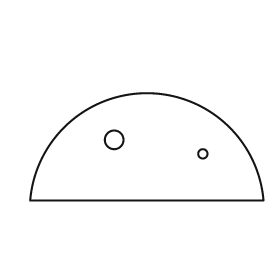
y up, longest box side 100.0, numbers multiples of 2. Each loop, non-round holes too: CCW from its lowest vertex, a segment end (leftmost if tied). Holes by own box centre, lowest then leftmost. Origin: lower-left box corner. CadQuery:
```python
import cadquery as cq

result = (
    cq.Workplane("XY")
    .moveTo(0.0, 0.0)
    .lineTo(100.0, 0.0)
    .threePointArc((50.0, 46.0), (0.0, 0.0))
    .close()
    .moveTo(74.0, 20.0)
    .circle(2.0)
    .moveTo(36.0, 26.0)
    .circle(4.0)
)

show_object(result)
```